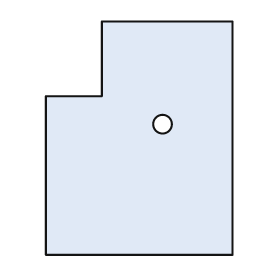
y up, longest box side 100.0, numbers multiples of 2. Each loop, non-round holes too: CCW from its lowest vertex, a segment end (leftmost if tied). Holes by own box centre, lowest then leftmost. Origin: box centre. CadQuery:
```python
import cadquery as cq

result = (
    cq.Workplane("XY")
    .moveTo(-40.0, -50.0)
    .lineTo(40.0, -50.0)
    .lineTo(40.0, 50.0)
    .lineTo(-16.0, 50.0)
    .lineTo(-16.0, 18.0)
    .lineTo(-40.0, 18.0)
    .close()
    .moveTo(10.0, 6.0)
    .circle(4.0)
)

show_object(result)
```